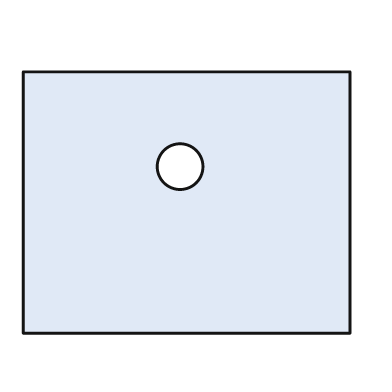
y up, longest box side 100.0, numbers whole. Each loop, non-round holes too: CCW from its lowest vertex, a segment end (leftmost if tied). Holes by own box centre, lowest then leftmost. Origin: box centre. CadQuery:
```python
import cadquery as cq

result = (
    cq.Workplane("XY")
    .moveTo(-50.0, -40.0)
    .lineTo(50.0, -40.0)
    .lineTo(50.0, 40.0)
    .lineTo(-50.0, 40.0)
    .close()
    .moveTo(-2.0, 11.0)
    .circle(7.0)
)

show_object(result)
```